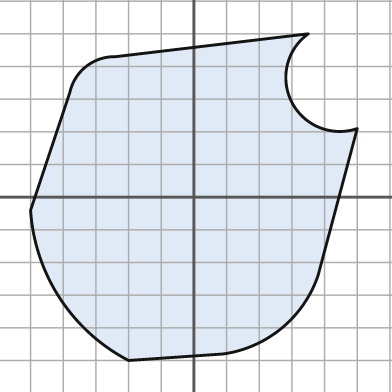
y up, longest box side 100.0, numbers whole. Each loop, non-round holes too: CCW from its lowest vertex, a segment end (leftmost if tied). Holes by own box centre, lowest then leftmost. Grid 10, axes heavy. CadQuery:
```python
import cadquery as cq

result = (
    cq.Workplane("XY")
    .moveTo(-20.0, -50.0)
    .lineTo(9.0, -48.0)
    .threePointArc((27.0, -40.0), (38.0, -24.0))
    .lineTo(50.0, 21.0)
    .threePointArc((30.0, 29.0), (35.0, 50.0))
    .lineTo(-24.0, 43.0)
    .threePointArc((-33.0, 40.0), (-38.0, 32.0))
    .lineTo(-50.0, -4.0)
    .threePointArc((-41.0, -31.0), (-20.0, -50.0))
    .close()
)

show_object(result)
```